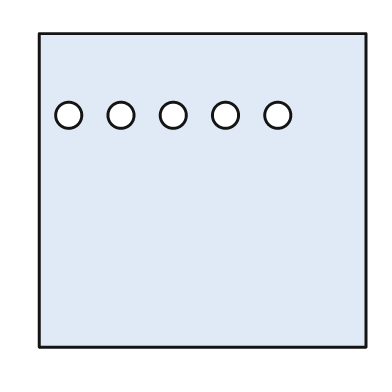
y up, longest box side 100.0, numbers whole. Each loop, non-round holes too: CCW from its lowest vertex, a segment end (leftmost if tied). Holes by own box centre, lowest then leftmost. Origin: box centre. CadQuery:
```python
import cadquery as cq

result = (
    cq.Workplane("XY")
    .moveTo(-50.0, -48.0)
    .lineTo(50.0, -48.0)
    .lineTo(50.0, 48.0)
    .lineTo(-50.0, 48.0)
    .close()
    .moveTo(-41.0, 23.0)
    .circle(4.0)
    .moveTo(-25.0, 23.0)
    .circle(4.0)
    .moveTo(-9.0, 23.0)
    .circle(4.0)
    .moveTo(7.0, 23.0)
    .circle(4.0)
    .moveTo(23.0, 23.0)
    .circle(4.0)
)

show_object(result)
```